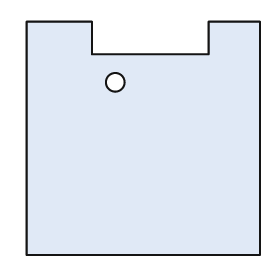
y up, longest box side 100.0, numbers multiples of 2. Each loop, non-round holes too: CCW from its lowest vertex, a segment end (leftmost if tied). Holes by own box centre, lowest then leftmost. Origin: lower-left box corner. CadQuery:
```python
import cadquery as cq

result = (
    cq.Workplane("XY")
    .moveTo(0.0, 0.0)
    .lineTo(100.0, 0.0)
    .lineTo(100.0, 100.0)
    .lineTo(78.0, 100.0)
    .lineTo(78.0, 86.0)
    .lineTo(28.0, 86.0)
    .lineTo(28.0, 100.0)
    .lineTo(0.0, 100.0)
    .close()
    .moveTo(38.0, 74.0)
    .circle(4.0)
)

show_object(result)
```